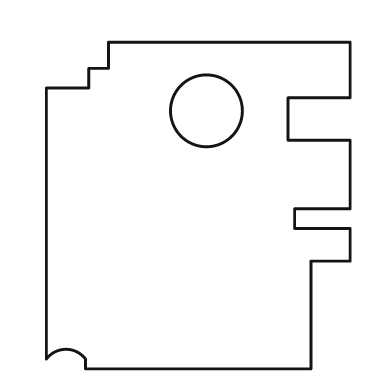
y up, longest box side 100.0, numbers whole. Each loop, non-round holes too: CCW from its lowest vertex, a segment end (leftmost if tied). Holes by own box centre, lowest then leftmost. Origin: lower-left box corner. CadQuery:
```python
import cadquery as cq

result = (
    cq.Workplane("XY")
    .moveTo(12.0, 0.0)
    .lineTo(81.0, 0.0)
    .lineTo(81.0, 33.0)
    .lineTo(93.0, 33.0)
    .lineTo(93.0, 43.0)
    .lineTo(76.0, 43.0)
    .lineTo(76.0, 49.0)
    .lineTo(93.0, 49.0)
    .lineTo(93.0, 70.0)
    .lineTo(74.0, 70.0)
    .lineTo(74.0, 83.0)
    .lineTo(93.0, 83.0)
    .lineTo(93.0, 100.0)
    .lineTo(19.0, 100.0)
    .lineTo(19.0, 92.0)
    .lineTo(13.0, 92.0)
    .lineTo(13.0, 86.0)
    .lineTo(0.0, 86.0)
    .lineTo(0.0, 3.0)
    .threePointArc((6.0, 6.0), (12.0, 3.0))
    .close()
    .moveTo(49.0, 79.0)
    .circle(11.0)
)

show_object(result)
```